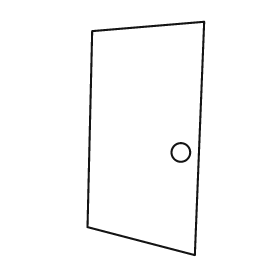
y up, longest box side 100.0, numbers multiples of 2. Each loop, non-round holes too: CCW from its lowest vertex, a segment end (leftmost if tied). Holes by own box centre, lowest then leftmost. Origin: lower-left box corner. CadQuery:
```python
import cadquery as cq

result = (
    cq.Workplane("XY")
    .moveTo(46.0, 0.0)
    .lineTo(50.0, 100.0)
    .lineTo(2.0, 96.0)
    .lineTo(0.0, 12.0)
    .close()
    .moveTo(40.0, 44.0)
    .circle(4.0)
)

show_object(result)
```